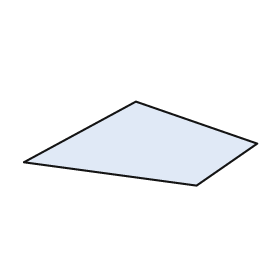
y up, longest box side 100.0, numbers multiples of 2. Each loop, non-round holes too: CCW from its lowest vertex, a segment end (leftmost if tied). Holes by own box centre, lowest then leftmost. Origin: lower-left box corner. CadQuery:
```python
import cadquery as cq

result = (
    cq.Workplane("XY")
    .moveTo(74.0, 0.0)
    .lineTo(100.0, 18.0)
    .lineTo(48.0, 36.0)
    .lineTo(0.0, 10.0)
    .close()
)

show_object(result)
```